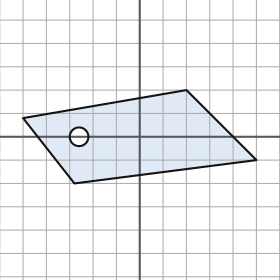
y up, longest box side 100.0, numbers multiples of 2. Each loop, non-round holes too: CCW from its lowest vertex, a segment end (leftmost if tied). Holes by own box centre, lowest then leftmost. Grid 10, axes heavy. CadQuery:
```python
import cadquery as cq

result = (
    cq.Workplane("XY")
    .moveTo(-28.0, -20.0)
    .lineTo(50.0, -10.0)
    .lineTo(20.0, 20.0)
    .lineTo(-50.0, 8.0)
    .close()
    .moveTo(-26.0, 0.0)
    .circle(4.0)
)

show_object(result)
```